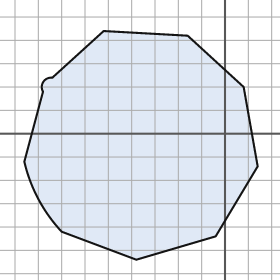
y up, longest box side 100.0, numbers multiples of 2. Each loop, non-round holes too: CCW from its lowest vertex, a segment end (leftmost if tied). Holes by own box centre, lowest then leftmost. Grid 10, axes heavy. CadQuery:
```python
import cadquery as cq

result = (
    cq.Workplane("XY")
    .moveTo(-38.0, -54.0)
    .lineTo(-4.0, -44.0)
    .lineTo(14.0, -14.0)
    .lineTo(8.0, 20.0)
    .lineTo(-16.0, 42.0)
    .lineTo(-52.0, 44.0)
    .lineTo(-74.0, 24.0)
    .threePointArc((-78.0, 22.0), (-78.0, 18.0))
    .lineTo(-86.0, -12.0)
    .threePointArc((-80.0, -28.0), (-70.0, -42.0))
    .close()
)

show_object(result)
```